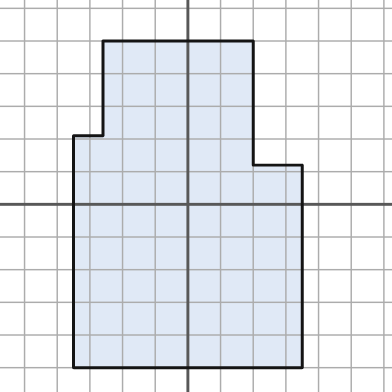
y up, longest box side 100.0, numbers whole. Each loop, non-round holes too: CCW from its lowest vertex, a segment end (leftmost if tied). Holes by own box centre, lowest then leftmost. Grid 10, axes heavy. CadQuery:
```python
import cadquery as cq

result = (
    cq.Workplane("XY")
    .moveTo(-35.0, -50.0)
    .lineTo(35.0, -50.0)
    .lineTo(35.0, 12.0)
    .lineTo(20.0, 12.0)
    .lineTo(20.0, 50.0)
    .lineTo(-26.0, 50.0)
    .lineTo(-26.0, 21.0)
    .lineTo(-35.0, 21.0)
    .close()
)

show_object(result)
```